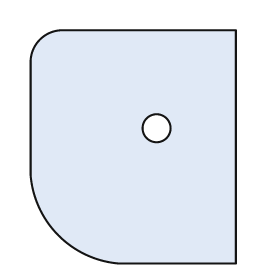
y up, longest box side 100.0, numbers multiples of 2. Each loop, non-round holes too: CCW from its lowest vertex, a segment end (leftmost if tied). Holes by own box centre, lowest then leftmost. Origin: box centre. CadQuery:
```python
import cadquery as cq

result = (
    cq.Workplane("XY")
    .moveTo(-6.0, -50.0)
    .lineTo(44.0, -50.0)
    .lineTo(44.0, 50.0)
    .lineTo(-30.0, 50.0)
    .threePointArc((-40.0, 46.0), (-44.0, 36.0))
    .lineTo(-44.0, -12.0)
    .threePointArc((-32.0, -38.0), (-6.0, -50.0))
    .close()
    .moveTo(10.0, 8.0)
    .circle(6.0)
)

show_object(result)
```